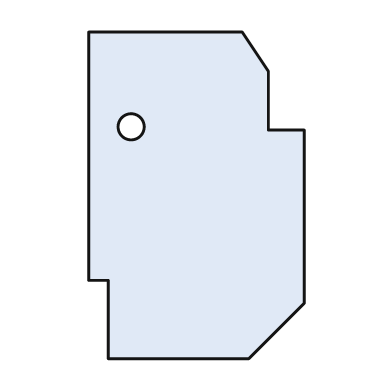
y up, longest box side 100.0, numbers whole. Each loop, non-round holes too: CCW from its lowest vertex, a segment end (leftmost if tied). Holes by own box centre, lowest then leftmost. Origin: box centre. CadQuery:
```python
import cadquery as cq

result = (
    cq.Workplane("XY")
    .moveTo(-27.0, -50.0)
    .lineTo(16.0, -50.0)
    .lineTo(33.0, -33.0)
    .lineTo(33.0, 20.0)
    .lineTo(22.0, 20.0)
    .lineTo(22.0, 38.0)
    .lineTo(14.0, 50.0)
    .lineTo(-33.0, 50.0)
    .lineTo(-33.0, -26.0)
    .lineTo(-27.0, -26.0)
    .close()
    .moveTo(-20.0, 21.0)
    .circle(4.0)
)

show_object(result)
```